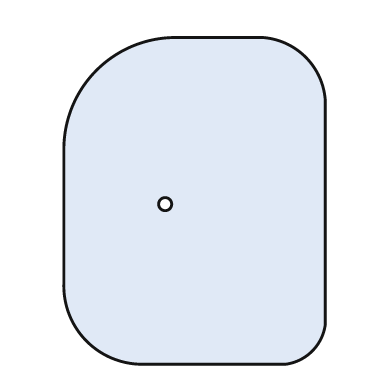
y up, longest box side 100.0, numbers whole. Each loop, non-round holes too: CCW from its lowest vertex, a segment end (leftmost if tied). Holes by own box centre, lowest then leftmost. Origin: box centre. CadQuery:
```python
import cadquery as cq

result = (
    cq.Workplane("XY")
    .moveTo(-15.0, -50.0)
    .lineTo(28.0, -50.0)
    .threePointArc((36.0, -46.0), (40.0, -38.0))
    .lineTo(40.0, 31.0)
    .threePointArc((34.0, 44.0), (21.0, 50.0))
    .lineTo(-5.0, 50.0)
    .threePointArc((-30.0, 40.0), (-40.0, 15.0))
    .lineTo(-40.0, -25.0)
    .threePointArc((-33.0, -43.0), (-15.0, -50.0))
    .close()
    .moveTo(-9.0, -1.0)
    .circle(2.0)
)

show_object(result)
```